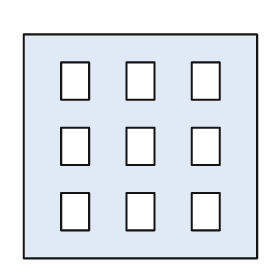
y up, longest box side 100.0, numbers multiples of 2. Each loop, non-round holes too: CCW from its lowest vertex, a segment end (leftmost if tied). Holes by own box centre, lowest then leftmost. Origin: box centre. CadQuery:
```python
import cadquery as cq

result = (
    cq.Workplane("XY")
    .moveTo(-50.0, -48.0)
    .lineTo(50.0, -48.0)
    .lineTo(50.0, 48.0)
    .lineTo(-50.0, 48.0)
    .close()
    .moveTo(-34.0, -36.0)
    .lineTo(-22.0, -36.0)
    .lineTo(-22.0, -20.0)
    .lineTo(-34.0, -20.0)
    .close()
    .moveTo(-6.0, -36.0)
    .lineTo(6.0, -36.0)
    .lineTo(6.0, -20.0)
    .lineTo(-6.0, -20.0)
    .close()
    .moveTo(22.0, -36.0)
    .lineTo(34.0, -36.0)
    .lineTo(34.0, -20.0)
    .lineTo(22.0, -20.0)
    .close()
    .moveTo(-34.0, -8.0)
    .lineTo(-22.0, -8.0)
    .lineTo(-22.0, 8.0)
    .lineTo(-34.0, 8.0)
    .close()
    .moveTo(-6.0, -8.0)
    .lineTo(6.0, -8.0)
    .lineTo(6.0, 8.0)
    .lineTo(-6.0, 8.0)
    .close()
    .moveTo(22.0, -8.0)
    .lineTo(34.0, -8.0)
    .lineTo(34.0, 8.0)
    .lineTo(22.0, 8.0)
    .close()
    .moveTo(-34.0, 20.0)
    .lineTo(-22.0, 20.0)
    .lineTo(-22.0, 36.0)
    .lineTo(-34.0, 36.0)
    .close()
    .moveTo(-6.0, 20.0)
    .lineTo(6.0, 20.0)
    .lineTo(6.0, 36.0)
    .lineTo(-6.0, 36.0)
    .close()
    .moveTo(22.0, 20.0)
    .lineTo(34.0, 20.0)
    .lineTo(34.0, 36.0)
    .lineTo(22.0, 36.0)
    .close()
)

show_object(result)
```